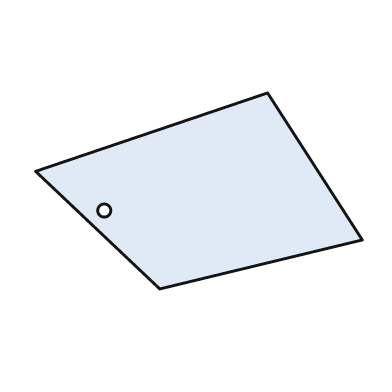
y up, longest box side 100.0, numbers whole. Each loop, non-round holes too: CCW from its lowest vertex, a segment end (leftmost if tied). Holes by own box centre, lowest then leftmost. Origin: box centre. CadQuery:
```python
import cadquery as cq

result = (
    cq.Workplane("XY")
    .moveTo(-12.0, -30.0)
    .lineTo(50.0, -15.0)
    .lineTo(21.0, 30.0)
    .lineTo(-50.0, 6.0)
    .close()
    .moveTo(-29.0, -6.0)
    .circle(2.0)
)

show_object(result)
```